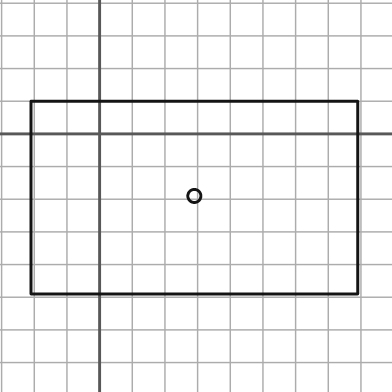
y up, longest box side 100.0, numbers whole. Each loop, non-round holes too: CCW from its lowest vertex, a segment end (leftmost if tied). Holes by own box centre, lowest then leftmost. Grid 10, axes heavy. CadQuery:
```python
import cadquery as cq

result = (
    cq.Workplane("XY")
    .moveTo(-21.0, -49.0)
    .lineTo(79.0, -49.0)
    .lineTo(79.0, 10.0)
    .lineTo(-21.0, 10.0)
    .close()
    .moveTo(29.0, -19.0)
    .circle(2.0)
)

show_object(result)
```